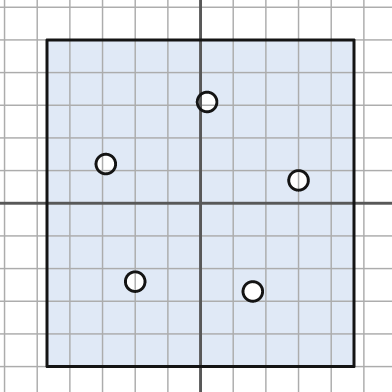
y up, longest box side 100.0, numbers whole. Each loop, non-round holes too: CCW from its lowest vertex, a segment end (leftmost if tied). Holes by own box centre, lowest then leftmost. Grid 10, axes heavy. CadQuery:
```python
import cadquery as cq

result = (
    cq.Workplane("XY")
    .moveTo(-47.0, -50.0)
    .lineTo(47.0, -50.0)
    .lineTo(47.0, 50.0)
    .lineTo(-47.0, 50.0)
    .close()
    .moveTo(16.0, -27.0)
    .circle(3.0)
    .moveTo(-20.0, -24.0)
    .circle(3.0)
    .moveTo(30.0, 7.0)
    .circle(3.0)
    .moveTo(-29.0, 12.0)
    .circle(3.0)
    .moveTo(2.0, 31.0)
    .circle(3.0)
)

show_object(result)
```